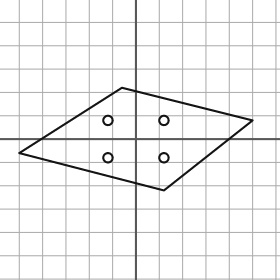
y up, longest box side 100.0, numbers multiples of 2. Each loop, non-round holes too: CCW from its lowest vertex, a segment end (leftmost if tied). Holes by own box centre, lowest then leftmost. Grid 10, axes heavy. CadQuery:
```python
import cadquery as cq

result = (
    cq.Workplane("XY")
    .moveTo(12.0, -22.0)
    .lineTo(50.0, 8.0)
    .lineTo(-6.0, 22.0)
    .lineTo(-50.0, -6.0)
    .close()
    .moveTo(-12.0, -8.0)
    .circle(2.0)
    .moveTo(12.0, -8.0)
    .circle(2.0)
    .moveTo(-12.0, 8.0)
    .circle(2.0)
    .moveTo(12.0, 8.0)
    .circle(2.0)
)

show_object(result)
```